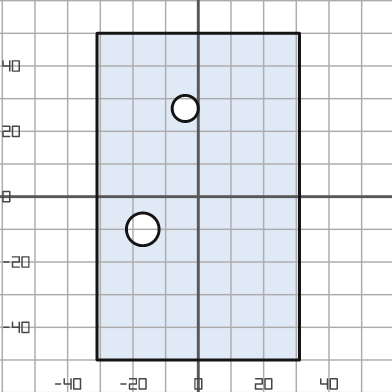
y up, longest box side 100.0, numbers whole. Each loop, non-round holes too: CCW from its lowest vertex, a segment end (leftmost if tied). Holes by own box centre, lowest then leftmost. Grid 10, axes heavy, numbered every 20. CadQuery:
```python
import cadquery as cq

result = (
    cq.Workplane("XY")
    .moveTo(-31.0, -50.0)
    .lineTo(31.0, -50.0)
    .lineTo(31.0, 50.0)
    .lineTo(-31.0, 50.0)
    .close()
    .moveTo(-17.0, -10.0)
    .circle(5.0)
    .moveTo(-4.0, 27.0)
    .circle(4.0)
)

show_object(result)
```